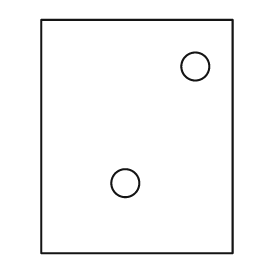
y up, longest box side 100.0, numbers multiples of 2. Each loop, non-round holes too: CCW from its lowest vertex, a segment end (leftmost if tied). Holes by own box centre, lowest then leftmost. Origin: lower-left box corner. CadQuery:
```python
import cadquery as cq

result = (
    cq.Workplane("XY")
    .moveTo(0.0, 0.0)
    .lineTo(82.0, 0.0)
    .lineTo(82.0, 100.0)
    .lineTo(0.0, 100.0)
    .close()
    .moveTo(36.0, 30.0)
    .circle(6.0)
    .moveTo(66.0, 80.0)
    .circle(6.0)
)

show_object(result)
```